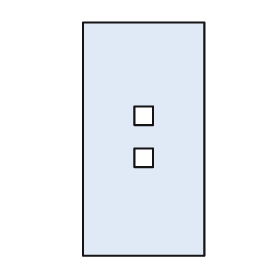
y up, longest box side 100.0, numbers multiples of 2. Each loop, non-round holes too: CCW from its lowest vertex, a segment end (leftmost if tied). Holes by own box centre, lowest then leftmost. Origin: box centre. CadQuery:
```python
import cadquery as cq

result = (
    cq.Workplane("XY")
    .moveTo(-26.0, -50.0)
    .lineTo(26.0, -50.0)
    .lineTo(26.0, 50.0)
    .lineTo(-26.0, 50.0)
    .close()
    .moveTo(-4.0, -12.0)
    .lineTo(4.0, -12.0)
    .lineTo(4.0, -4.0)
    .lineTo(-4.0, -4.0)
    .close()
    .moveTo(-4.0, 6.0)
    .lineTo(4.0, 6.0)
    .lineTo(4.0, 14.0)
    .lineTo(-4.0, 14.0)
    .close()
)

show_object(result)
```